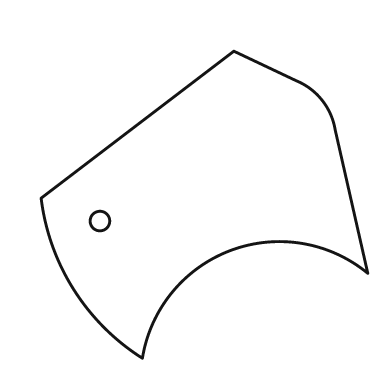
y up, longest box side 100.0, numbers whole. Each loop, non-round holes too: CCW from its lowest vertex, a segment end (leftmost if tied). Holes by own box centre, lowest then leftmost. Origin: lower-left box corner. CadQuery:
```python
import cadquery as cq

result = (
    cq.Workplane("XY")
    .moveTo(31.0, 0.0)
    .threePointArc((58.0, 33.0), (100.0, 26.0))
    .lineTo(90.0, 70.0)
    .threePointArc((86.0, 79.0), (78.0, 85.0))
    .lineTo(59.0, 94.0)
    .lineTo(0.0, 49.0)
    .threePointArc((10.0, 21.0), (31.0, 0.0))
    .close()
    .moveTo(18.0, 42.0)
    .circle(3.0)
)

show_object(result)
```